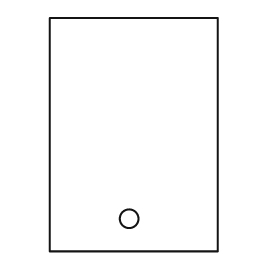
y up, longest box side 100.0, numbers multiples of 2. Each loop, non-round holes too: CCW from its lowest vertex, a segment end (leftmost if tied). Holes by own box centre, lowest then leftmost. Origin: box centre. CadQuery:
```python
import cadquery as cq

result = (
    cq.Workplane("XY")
    .moveTo(-36.0, -50.0)
    .lineTo(36.0, -50.0)
    .lineTo(36.0, 50.0)
    .lineTo(-36.0, 50.0)
    .close()
    .moveTo(-2.0, -36.0)
    .circle(4.0)
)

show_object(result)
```